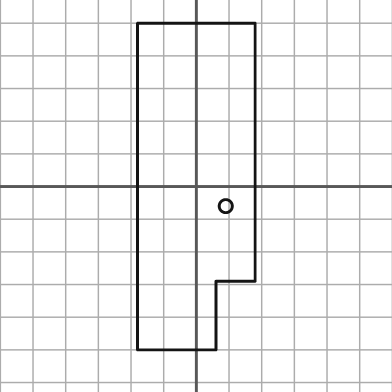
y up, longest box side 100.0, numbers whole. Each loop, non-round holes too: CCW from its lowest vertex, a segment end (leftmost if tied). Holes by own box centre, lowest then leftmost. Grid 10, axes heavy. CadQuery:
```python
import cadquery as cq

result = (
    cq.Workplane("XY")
    .moveTo(-18.0, -50.0)
    .lineTo(6.0, -50.0)
    .lineTo(6.0, -29.0)
    .lineTo(18.0, -29.0)
    .lineTo(18.0, 50.0)
    .lineTo(-18.0, 50.0)
    .close()
    .moveTo(9.0, -6.0)
    .circle(2.0)
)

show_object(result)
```